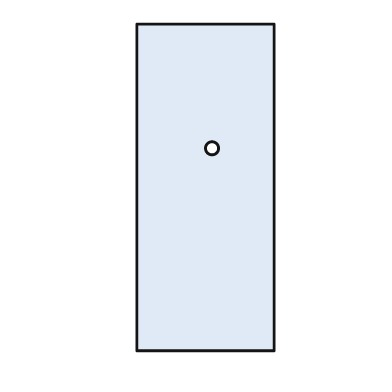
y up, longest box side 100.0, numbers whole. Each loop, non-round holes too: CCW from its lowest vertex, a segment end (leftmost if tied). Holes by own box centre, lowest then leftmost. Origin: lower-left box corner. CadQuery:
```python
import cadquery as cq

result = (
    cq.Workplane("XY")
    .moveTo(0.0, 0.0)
    .lineTo(42.0, 0.0)
    .lineTo(42.0, 100.0)
    .lineTo(0.0, 100.0)
    .close()
    .moveTo(23.0, 62.0)
    .circle(2.0)
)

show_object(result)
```